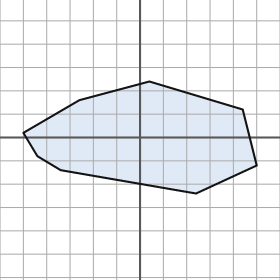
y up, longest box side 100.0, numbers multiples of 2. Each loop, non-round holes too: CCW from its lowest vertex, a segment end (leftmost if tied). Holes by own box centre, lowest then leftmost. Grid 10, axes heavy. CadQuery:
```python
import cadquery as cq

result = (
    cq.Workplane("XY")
    .moveTo(24.0, -24.0)
    .lineTo(50.0, -12.0)
    .lineTo(44.0, 12.0)
    .lineTo(4.0, 24.0)
    .lineTo(-26.0, 16.0)
    .lineTo(-50.0, 2.0)
    .lineTo(-44.0, -8.0)
    .lineTo(-34.0, -14.0)
    .close()
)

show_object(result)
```